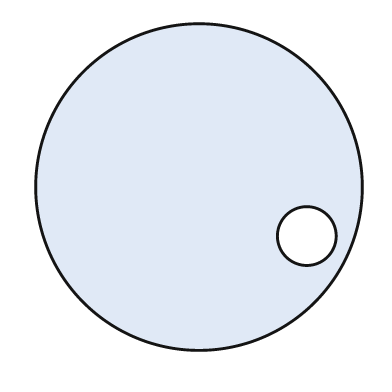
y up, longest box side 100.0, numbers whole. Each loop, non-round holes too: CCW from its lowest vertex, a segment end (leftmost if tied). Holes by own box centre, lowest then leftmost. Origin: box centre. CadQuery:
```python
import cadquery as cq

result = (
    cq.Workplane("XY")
    .moveTo(0.0, 0.0)
    .circle(50.0)
    .moveTo(33.0, -15.0)
    .circle(9.0)
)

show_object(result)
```